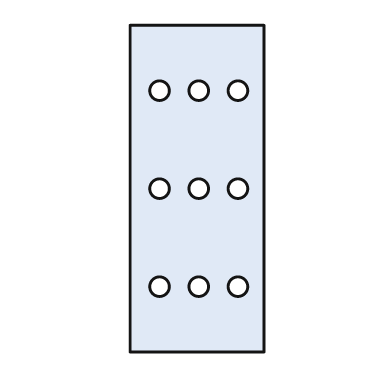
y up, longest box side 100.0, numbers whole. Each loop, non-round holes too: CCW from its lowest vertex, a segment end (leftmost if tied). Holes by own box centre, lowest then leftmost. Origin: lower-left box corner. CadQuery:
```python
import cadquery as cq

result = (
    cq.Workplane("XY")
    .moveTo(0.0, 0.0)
    .lineTo(41.0, 0.0)
    .lineTo(41.0, 100.0)
    .lineTo(0.0, 100.0)
    .close()
    .moveTo(9.0, 20.0)
    .circle(3.0)
    .moveTo(21.0, 20.0)
    .circle(3.0)
    .moveTo(33.0, 20.0)
    .circle(3.0)
    .moveTo(9.0, 50.0)
    .circle(3.0)
    .moveTo(21.0, 50.0)
    .circle(3.0)
    .moveTo(33.0, 50.0)
    .circle(3.0)
    .moveTo(9.0, 80.0)
    .circle(3.0)
    .moveTo(21.0, 80.0)
    .circle(3.0)
    .moveTo(33.0, 80.0)
    .circle(3.0)
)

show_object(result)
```